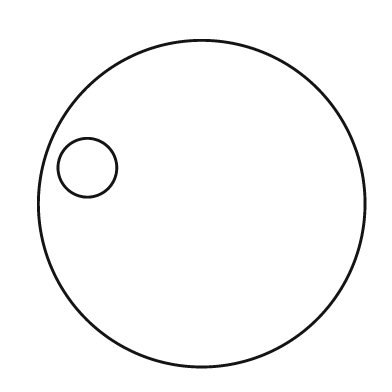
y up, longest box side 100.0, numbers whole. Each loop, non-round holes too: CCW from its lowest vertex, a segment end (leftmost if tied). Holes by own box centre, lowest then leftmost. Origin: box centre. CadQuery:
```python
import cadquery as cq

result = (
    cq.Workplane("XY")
    .moveTo(0.0, 0.0)
    .circle(50.0)
    .moveTo(-35.0, 11.0)
    .circle(9.0)
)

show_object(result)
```